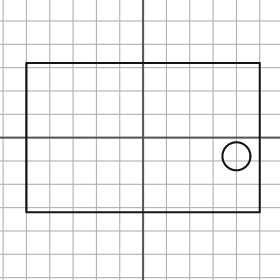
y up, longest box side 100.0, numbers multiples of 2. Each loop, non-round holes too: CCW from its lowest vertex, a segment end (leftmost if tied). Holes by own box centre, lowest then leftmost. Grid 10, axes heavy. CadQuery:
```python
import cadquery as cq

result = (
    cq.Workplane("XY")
    .moveTo(-50.0, -32.0)
    .lineTo(50.0, -32.0)
    .lineTo(50.0, 32.0)
    .lineTo(-50.0, 32.0)
    .close()
    .moveTo(40.0, -8.0)
    .circle(6.0)
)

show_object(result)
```